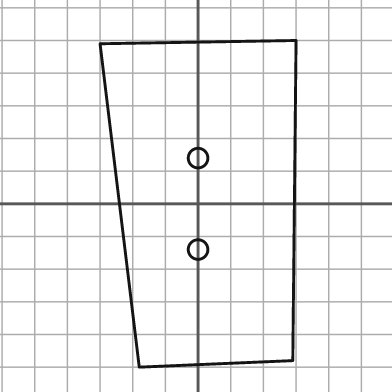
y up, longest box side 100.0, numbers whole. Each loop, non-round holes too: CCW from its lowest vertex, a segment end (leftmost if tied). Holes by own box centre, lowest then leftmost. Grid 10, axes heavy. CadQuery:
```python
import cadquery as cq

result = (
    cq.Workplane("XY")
    .moveTo(-18.0, -50.0)
    .lineTo(29.0, -48.0)
    .lineTo(30.0, 50.0)
    .lineTo(-30.0, 49.0)
    .close()
    .moveTo(0.0, -14.0)
    .circle(3.0)
    .moveTo(0.0, 14.0)
    .circle(3.0)
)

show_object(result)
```